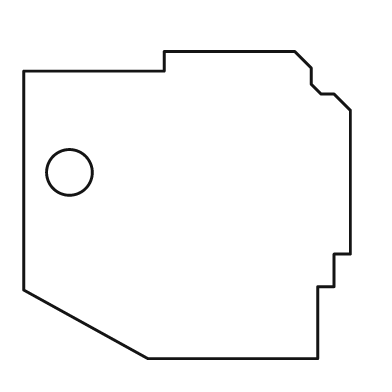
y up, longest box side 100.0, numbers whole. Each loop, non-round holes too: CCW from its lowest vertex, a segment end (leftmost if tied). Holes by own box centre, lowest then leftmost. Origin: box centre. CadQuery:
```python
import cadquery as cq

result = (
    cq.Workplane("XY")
    .moveTo(-12.0, -47.0)
    .lineTo(40.0, -47.0)
    .lineTo(40.0, -25.0)
    .lineTo(45.0, -25.0)
    .lineTo(45.0, -15.0)
    .lineTo(50.0, -15.0)
    .lineTo(50.0, 29.0)
    .lineTo(45.0, 34.0)
    .lineTo(41.0, 34.0)
    .lineTo(38.0, 37.0)
    .lineTo(38.0, 42.0)
    .lineTo(33.0, 47.0)
    .lineTo(-7.0, 47.0)
    .lineTo(-7.0, 41.0)
    .lineTo(-50.0, 41.0)
    .lineTo(-50.0, -26.0)
    .close()
    .moveTo(-36.0, 10.0)
    .circle(7.0)
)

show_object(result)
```